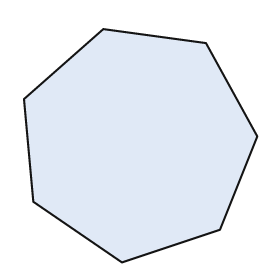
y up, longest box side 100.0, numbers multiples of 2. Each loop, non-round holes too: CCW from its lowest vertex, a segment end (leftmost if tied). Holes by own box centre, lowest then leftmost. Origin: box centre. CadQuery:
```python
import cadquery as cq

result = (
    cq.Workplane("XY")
    .moveTo(-8.0, -50.0)
    .lineTo(34.0, -36.0)
    .lineTo(50.0, 4.0)
    .lineTo(28.0, 44.0)
    .lineTo(-16.0, 50.0)
    .lineTo(-50.0, 20.0)
    .lineTo(-46.0, -24.0)
    .close()
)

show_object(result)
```